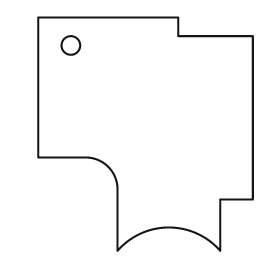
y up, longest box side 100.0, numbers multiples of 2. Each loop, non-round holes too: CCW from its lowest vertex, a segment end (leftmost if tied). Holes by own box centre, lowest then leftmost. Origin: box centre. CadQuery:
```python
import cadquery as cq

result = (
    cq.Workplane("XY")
    .moveTo(-12.0, -50.0)
    .threePointArc((10.0, -40.0), (32.0, -50.0))
    .lineTo(32.0, -28.0)
    .lineTo(46.0, -28.0)
    .lineTo(46.0, 42.0)
    .lineTo(14.0, 42.0)
    .lineTo(14.0, 50.0)
    .lineTo(-46.0, 50.0)
    .lineTo(-46.0, -10.0)
    .lineTo(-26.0, -10.0)
    .threePointArc((-16.0, -14.0), (-12.0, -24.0))
    .close()
    .moveTo(-32.0, 38.0)
    .circle(4.0)
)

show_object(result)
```